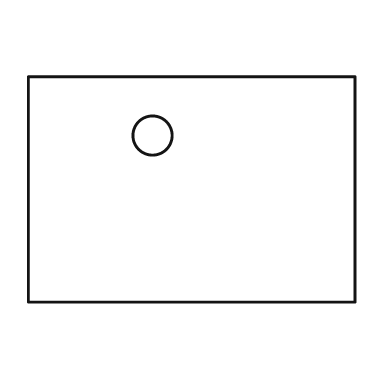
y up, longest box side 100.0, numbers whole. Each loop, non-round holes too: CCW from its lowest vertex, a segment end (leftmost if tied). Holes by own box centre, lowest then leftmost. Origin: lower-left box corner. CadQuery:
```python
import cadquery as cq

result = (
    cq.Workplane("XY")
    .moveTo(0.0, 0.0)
    .lineTo(100.0, 0.0)
    .lineTo(100.0, 69.0)
    .lineTo(0.0, 69.0)
    .close()
    .moveTo(38.0, 51.0)
    .circle(6.0)
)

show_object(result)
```